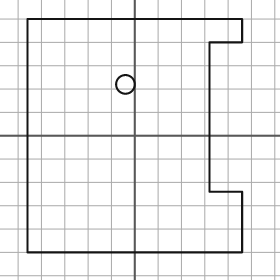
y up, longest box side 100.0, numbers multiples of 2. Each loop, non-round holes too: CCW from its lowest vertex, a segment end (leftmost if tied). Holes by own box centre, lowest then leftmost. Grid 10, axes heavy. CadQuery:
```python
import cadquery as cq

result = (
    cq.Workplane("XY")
    .moveTo(-46.0, -50.0)
    .lineTo(46.0, -50.0)
    .lineTo(46.0, -24.0)
    .lineTo(32.0, -24.0)
    .lineTo(32.0, 40.0)
    .lineTo(46.0, 40.0)
    .lineTo(46.0, 50.0)
    .lineTo(-46.0, 50.0)
    .close()
    .moveTo(-4.0, 22.0)
    .circle(4.0)
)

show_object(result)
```